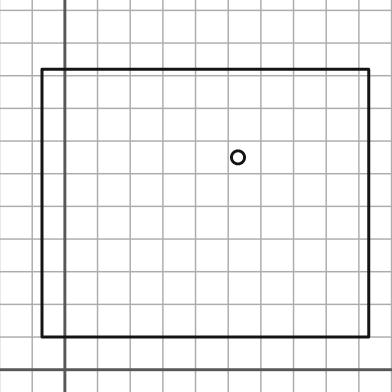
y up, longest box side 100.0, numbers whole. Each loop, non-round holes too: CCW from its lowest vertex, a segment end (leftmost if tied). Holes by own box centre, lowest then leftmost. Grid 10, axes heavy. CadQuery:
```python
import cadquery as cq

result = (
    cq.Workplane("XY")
    .moveTo(-7.0, 10.0)
    .lineTo(93.0, 10.0)
    .lineTo(93.0, 92.0)
    .lineTo(-7.0, 92.0)
    .close()
    .moveTo(53.0, 65.0)
    .circle(2.0)
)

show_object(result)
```